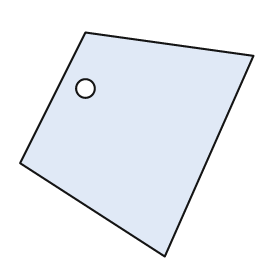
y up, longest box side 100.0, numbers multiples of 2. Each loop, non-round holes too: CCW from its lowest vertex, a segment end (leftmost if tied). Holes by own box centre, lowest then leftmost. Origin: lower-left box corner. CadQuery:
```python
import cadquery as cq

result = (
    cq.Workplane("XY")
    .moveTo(62.0, 0.0)
    .lineTo(100.0, 86.0)
    .lineTo(28.0, 96.0)
    .lineTo(0.0, 40.0)
    .close()
    .moveTo(28.0, 72.0)
    .circle(4.0)
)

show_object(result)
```